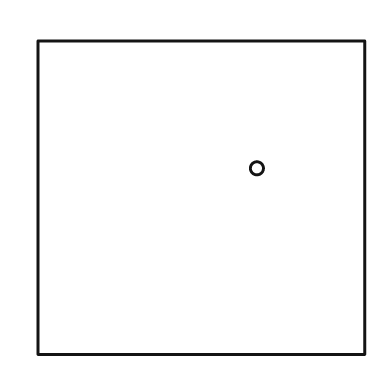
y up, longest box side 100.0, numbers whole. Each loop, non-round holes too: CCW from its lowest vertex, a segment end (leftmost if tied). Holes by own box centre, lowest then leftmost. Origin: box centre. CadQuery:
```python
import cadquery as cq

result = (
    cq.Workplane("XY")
    .moveTo(-50.0, -48.0)
    .lineTo(50.0, -48.0)
    .lineTo(50.0, 48.0)
    .lineTo(-50.0, 48.0)
    .close()
    .moveTo(17.0, 9.0)
    .circle(2.0)
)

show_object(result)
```